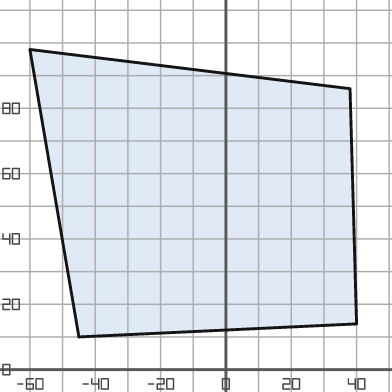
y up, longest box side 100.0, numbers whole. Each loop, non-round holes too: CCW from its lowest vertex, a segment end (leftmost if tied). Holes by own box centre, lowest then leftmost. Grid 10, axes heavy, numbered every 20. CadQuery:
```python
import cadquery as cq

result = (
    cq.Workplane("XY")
    .moveTo(-45.0, 10.0)
    .lineTo(40.0, 14.0)
    .lineTo(38.0, 86.0)
    .lineTo(-60.0, 98.0)
    .close()
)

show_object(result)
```